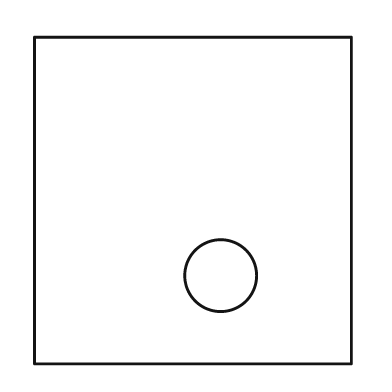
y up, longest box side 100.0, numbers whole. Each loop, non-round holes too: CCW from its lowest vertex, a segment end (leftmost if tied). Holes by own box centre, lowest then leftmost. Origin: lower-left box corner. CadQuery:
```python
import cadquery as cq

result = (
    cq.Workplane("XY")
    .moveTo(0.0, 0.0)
    .lineTo(97.0, 0.0)
    .lineTo(97.0, 100.0)
    .lineTo(0.0, 100.0)
    .close()
    .moveTo(57.0, 27.0)
    .circle(11.0)
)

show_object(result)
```